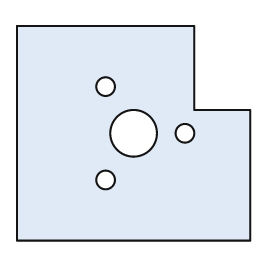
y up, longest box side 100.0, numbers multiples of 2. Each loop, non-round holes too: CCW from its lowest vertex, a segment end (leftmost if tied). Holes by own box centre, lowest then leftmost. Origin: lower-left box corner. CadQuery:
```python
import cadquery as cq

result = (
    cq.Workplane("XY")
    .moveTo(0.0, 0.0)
    .lineTo(100.0, 0.0)
    .lineTo(100.0, 56.0)
    .lineTo(76.0, 56.0)
    .lineTo(76.0, 92.0)
    .lineTo(0.0, 92.0)
    .close()
    .moveTo(38.0, 26.0)
    .circle(4.0)
    .moveTo(50.0, 46.0)
    .circle(10.0)
    .moveTo(72.0, 46.0)
    .circle(4.0)
    .moveTo(38.0, 66.0)
    .circle(4.0)
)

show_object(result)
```